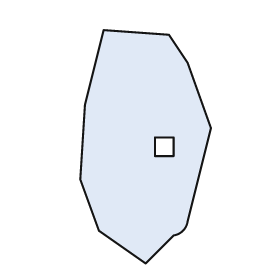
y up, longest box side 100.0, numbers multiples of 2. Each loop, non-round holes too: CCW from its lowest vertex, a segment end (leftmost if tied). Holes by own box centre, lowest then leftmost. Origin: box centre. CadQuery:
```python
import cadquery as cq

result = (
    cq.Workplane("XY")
    .moveTo(0.0, -50.0)
    .lineTo(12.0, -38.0)
    .threePointArc((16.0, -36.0), (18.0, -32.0))
    .lineTo(28.0, 8.0)
    .lineTo(18.0, 36.0)
    .lineTo(10.0, 48.0)
    .lineTo(-18.0, 50.0)
    .lineTo(-26.0, 18.0)
    .lineTo(-28.0, -14.0)
    .lineTo(-20.0, -36.0)
    .close()
    .moveTo(4.0, -4.0)
    .lineTo(12.0, -4.0)
    .lineTo(12.0, 4.0)
    .lineTo(4.0, 4.0)
    .close()
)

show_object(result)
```